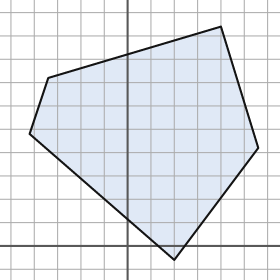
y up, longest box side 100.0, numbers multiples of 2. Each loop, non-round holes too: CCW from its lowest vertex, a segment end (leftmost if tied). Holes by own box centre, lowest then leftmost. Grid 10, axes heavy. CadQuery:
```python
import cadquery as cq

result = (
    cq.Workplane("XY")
    .moveTo(20.0, -6.0)
    .lineTo(56.0, 42.0)
    .lineTo(40.0, 94.0)
    .lineTo(-34.0, 72.0)
    .lineTo(-42.0, 48.0)
    .close()
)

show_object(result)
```